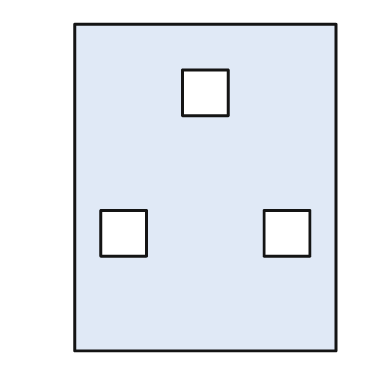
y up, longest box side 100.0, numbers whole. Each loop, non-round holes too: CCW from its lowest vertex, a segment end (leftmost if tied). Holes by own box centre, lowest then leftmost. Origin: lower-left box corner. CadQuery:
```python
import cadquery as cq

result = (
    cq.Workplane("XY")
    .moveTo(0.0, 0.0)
    .lineTo(80.0, 0.0)
    .lineTo(80.0, 100.0)
    .lineTo(0.0, 100.0)
    .close()
    .moveTo(8.0, 29.0)
    .lineTo(22.0, 29.0)
    .lineTo(22.0, 43.0)
    .lineTo(8.0, 43.0)
    .close()
    .moveTo(58.0, 29.0)
    .lineTo(72.0, 29.0)
    .lineTo(72.0, 43.0)
    .lineTo(58.0, 43.0)
    .close()
    .moveTo(33.0, 72.0)
    .lineTo(47.0, 72.0)
    .lineTo(47.0, 86.0)
    .lineTo(33.0, 86.0)
    .close()
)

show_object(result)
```